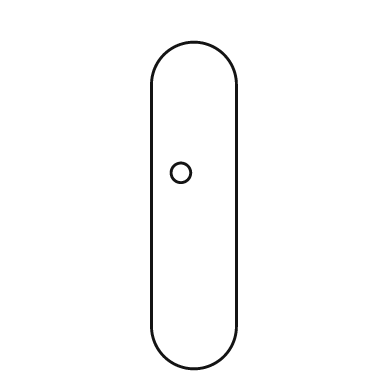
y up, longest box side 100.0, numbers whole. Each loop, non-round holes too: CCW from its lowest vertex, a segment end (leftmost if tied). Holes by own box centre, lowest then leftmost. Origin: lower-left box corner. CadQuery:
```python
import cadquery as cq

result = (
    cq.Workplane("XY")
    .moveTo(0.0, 13.0)
    .threePointArc((13.0, 0.0), (26.0, 13.0))
    .lineTo(26.0, 87.0)
    .threePointArc((13.0, 100.0), (0.0, 87.0))
    .close()
    .moveTo(9.0, 60.0)
    .circle(3.0)
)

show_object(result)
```